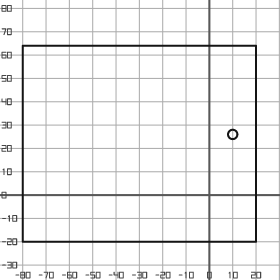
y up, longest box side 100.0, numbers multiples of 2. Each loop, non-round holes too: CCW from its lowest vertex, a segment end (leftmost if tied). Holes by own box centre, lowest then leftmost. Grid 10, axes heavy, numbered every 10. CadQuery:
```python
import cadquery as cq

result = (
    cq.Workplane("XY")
    .moveTo(-80.0, -20.0)
    .lineTo(20.0, -20.0)
    .lineTo(20.0, 64.0)
    .lineTo(-80.0, 64.0)
    .close()
    .moveTo(10.0, 26.0)
    .circle(2.0)
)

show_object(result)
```